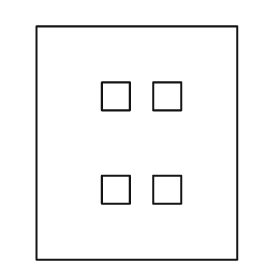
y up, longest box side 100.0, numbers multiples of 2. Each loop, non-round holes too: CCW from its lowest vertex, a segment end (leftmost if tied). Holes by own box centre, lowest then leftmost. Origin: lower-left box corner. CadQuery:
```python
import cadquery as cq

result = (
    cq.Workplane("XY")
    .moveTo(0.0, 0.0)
    .lineTo(86.0, 0.0)
    .lineTo(86.0, 100.0)
    .lineTo(0.0, 100.0)
    .close()
    .moveTo(28.0, 24.0)
    .lineTo(40.0, 24.0)
    .lineTo(40.0, 36.0)
    .lineTo(28.0, 36.0)
    .close()
    .moveTo(50.0, 24.0)
    .lineTo(62.0, 24.0)
    .lineTo(62.0, 36.0)
    .lineTo(50.0, 36.0)
    .close()
    .moveTo(28.0, 64.0)
    .lineTo(40.0, 64.0)
    .lineTo(40.0, 76.0)
    .lineTo(28.0, 76.0)
    .close()
    .moveTo(50.0, 64.0)
    .lineTo(62.0, 64.0)
    .lineTo(62.0, 76.0)
    .lineTo(50.0, 76.0)
    .close()
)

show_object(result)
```